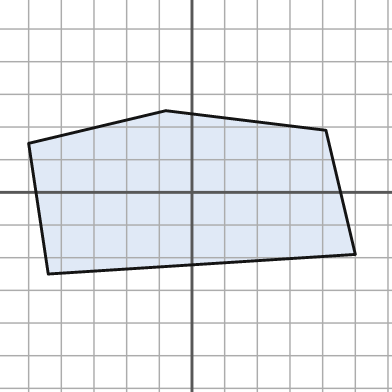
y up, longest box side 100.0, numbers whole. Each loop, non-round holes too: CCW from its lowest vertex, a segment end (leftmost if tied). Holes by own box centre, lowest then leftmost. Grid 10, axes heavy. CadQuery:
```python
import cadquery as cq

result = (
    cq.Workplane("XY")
    .moveTo(-44.0, -25.0)
    .lineTo(50.0, -19.0)
    .lineTo(41.0, 19.0)
    .lineTo(-8.0, 25.0)
    .lineTo(-50.0, 15.0)
    .close()
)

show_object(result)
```